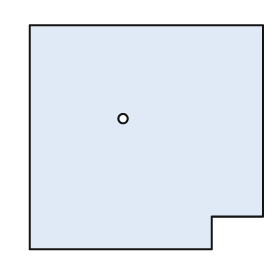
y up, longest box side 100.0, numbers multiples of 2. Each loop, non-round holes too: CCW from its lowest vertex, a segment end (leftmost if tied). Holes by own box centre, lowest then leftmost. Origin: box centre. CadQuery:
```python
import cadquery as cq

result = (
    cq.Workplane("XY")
    .moveTo(-50.0, -48.0)
    .lineTo(28.0, -48.0)
    .lineTo(28.0, -34.0)
    .lineTo(50.0, -34.0)
    .lineTo(50.0, 48.0)
    .lineTo(-50.0, 48.0)
    .close()
    .moveTo(-10.0, 8.0)
    .circle(2.0)
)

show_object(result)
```